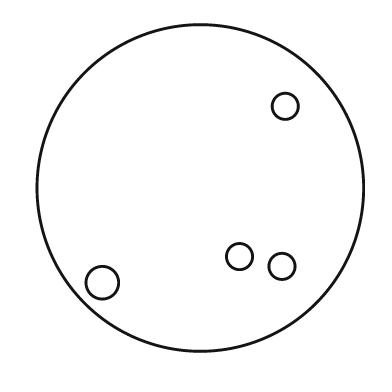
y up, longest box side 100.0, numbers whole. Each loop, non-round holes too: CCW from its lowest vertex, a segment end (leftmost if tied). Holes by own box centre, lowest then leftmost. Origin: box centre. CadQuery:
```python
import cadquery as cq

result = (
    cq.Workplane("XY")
    .moveTo(0.0, 0.0)
    .circle(50.0)
    .moveTo(-30.0, -29.0)
    .circle(5.0)
    .moveTo(25.0, -24.0)
    .circle(4.0)
    .moveTo(12.0, -21.0)
    .circle(4.0)
    .moveTo(26.0, 25.0)
    .circle(4.0)
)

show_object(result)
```